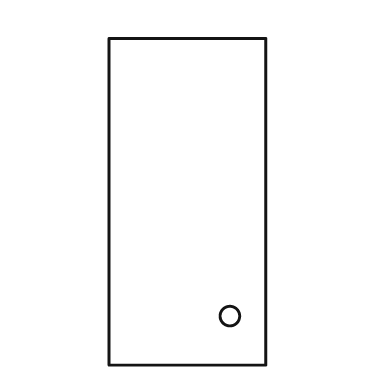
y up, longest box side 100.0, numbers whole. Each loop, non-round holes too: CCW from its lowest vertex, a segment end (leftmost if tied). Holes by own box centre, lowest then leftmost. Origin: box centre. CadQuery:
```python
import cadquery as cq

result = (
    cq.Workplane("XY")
    .moveTo(-24.0, -50.0)
    .lineTo(24.0, -50.0)
    .lineTo(24.0, 50.0)
    .lineTo(-24.0, 50.0)
    .close()
    .moveTo(13.0, -35.0)
    .circle(3.0)
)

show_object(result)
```